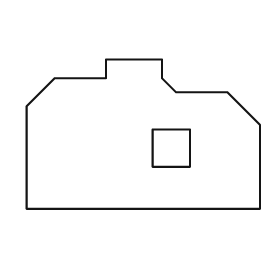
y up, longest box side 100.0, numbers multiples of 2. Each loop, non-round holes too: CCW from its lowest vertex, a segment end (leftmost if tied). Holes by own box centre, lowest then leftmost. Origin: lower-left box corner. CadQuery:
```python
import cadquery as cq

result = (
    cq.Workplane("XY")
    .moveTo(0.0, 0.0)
    .lineTo(100.0, 0.0)
    .lineTo(100.0, 36.0)
    .lineTo(86.0, 50.0)
    .lineTo(64.0, 50.0)
    .lineTo(58.0, 56.0)
    .lineTo(58.0, 64.0)
    .lineTo(34.0, 64.0)
    .lineTo(34.0, 56.0)
    .lineTo(12.0, 56.0)
    .lineTo(0.0, 44.0)
    .close()
    .moveTo(54.0, 18.0)
    .lineTo(70.0, 18.0)
    .lineTo(70.0, 34.0)
    .lineTo(54.0, 34.0)
    .close()
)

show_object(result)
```